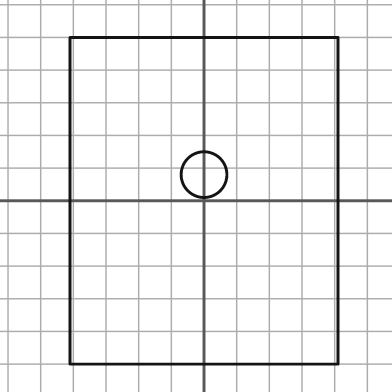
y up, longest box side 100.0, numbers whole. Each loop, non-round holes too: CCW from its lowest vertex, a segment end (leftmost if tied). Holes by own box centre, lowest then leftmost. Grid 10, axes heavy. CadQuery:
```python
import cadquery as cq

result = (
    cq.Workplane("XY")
    .moveTo(-41.0, -50.0)
    .lineTo(41.0, -50.0)
    .lineTo(41.0, 50.0)
    .lineTo(-41.0, 50.0)
    .close()
    .moveTo(0.0, 8.0)
    .circle(7.0)
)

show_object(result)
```